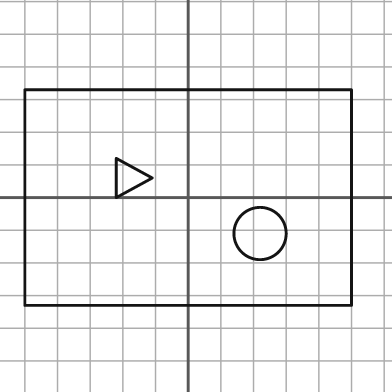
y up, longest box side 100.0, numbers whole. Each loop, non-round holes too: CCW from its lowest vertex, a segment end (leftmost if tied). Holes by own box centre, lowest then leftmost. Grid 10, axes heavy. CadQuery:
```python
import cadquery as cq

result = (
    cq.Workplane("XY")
    .moveTo(-50.0, -33.0)
    .lineTo(50.0, -33.0)
    .lineTo(50.0, 33.0)
    .lineTo(-50.0, 33.0)
    .close()
    .moveTo(22.0, -11.0)
    .circle(8.0)
    .moveTo(-22.0, 0.0)
    .lineTo(-11.0, 6.0)
    .lineTo(-22.0, 12.0)
    .close()
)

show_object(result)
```